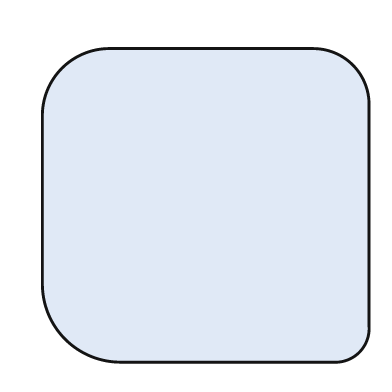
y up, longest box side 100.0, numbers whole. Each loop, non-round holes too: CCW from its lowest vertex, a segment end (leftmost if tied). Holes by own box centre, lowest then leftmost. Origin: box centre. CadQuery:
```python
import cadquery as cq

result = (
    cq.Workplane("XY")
    .moveTo(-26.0, -48.0)
    .lineTo(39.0, -48.0)
    .threePointArc((47.0, -45.0), (50.0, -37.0))
    .lineTo(50.0, 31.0)
    .threePointArc((45.0, 43.0), (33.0, 48.0))
    .lineTo(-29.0, 48.0)
    .threePointArc((-44.0, 42.0), (-50.0, 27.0))
    .lineTo(-50.0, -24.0)
    .threePointArc((-43.0, -41.0), (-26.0, -48.0))
    .close()
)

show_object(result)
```